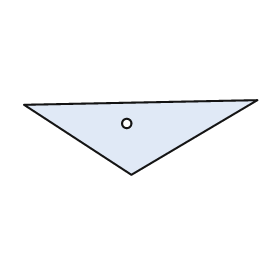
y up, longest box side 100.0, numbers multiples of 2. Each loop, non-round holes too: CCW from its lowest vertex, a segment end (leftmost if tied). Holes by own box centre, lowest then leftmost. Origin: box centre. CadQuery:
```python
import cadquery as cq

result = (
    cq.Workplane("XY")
    .moveTo(-4.0, -16.0)
    .lineTo(50.0, 16.0)
    .lineTo(-50.0, 14.0)
    .close()
    .moveTo(-6.0, 6.0)
    .circle(2.0)
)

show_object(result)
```